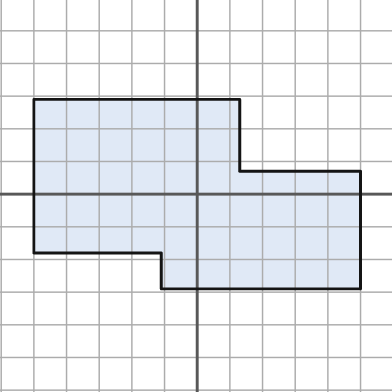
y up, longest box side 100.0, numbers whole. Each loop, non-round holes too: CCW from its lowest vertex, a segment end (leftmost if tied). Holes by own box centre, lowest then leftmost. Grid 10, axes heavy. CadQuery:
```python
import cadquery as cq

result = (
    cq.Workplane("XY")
    .moveTo(-11.0, -29.0)
    .lineTo(50.0, -29.0)
    .lineTo(50.0, 7.0)
    .lineTo(13.0, 7.0)
    .lineTo(13.0, 29.0)
    .lineTo(-50.0, 29.0)
    .lineTo(-50.0, -18.0)
    .lineTo(-11.0, -18.0)
    .close()
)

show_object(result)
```